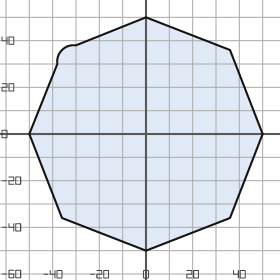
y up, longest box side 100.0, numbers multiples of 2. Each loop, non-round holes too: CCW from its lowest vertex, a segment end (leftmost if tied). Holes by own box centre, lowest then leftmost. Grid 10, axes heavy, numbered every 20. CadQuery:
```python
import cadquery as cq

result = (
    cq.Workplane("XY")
    .moveTo(0.0, -50.0)
    .lineTo(36.0, -36.0)
    .lineTo(50.0, 0.0)
    .lineTo(36.0, 36.0)
    .lineTo(0.0, 50.0)
    .lineTo(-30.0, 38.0)
    .threePointArc((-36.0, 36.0), (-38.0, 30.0))
    .lineTo(-50.0, 0.0)
    .lineTo(-36.0, -36.0)
    .close()
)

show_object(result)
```